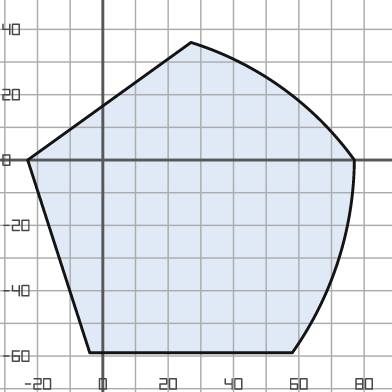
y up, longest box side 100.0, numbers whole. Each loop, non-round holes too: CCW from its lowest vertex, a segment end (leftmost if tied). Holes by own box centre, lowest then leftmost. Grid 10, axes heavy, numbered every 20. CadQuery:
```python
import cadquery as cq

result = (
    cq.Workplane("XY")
    .moveTo(-4.0, -59.0)
    .lineTo(58.0, -59.0)
    .threePointArc((72.0, -31.0), (77.0, 0.0))
    .threePointArc((55.0, 22.0), (27.0, 36.0))
    .lineTo(-23.0, 0.0)
    .close()
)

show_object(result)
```